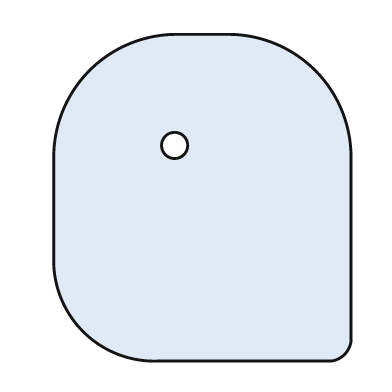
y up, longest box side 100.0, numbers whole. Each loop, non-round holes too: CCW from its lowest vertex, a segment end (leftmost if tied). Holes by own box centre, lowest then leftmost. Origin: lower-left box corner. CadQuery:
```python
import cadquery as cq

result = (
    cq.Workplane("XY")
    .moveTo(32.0, 0.0)
    .lineTo(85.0, 0.0)
    .threePointArc((89.0, 2.0), (91.0, 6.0))
    .lineTo(91.0, 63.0)
    .threePointArc((80.0, 89.0), (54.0, 100.0))
    .lineTo(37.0, 100.0)
    .threePointArc((11.0, 89.0), (0.0, 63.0))
    .lineTo(0.0, 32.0)
    .threePointArc((9.0, 9.0), (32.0, 0.0))
    .close()
    .moveTo(37.0, 66.0)
    .circle(4.0)
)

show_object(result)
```